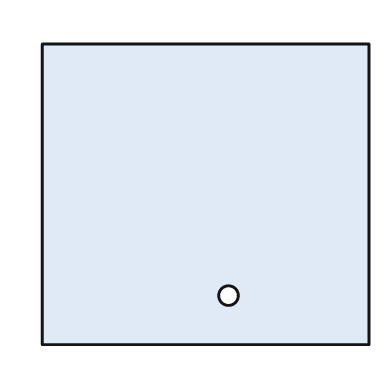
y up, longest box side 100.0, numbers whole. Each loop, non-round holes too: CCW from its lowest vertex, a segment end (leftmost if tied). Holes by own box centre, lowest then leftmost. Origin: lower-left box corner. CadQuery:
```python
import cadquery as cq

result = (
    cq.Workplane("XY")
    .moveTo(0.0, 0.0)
    .lineTo(100.0, 0.0)
    .lineTo(100.0, 92.0)
    .lineTo(0.0, 92.0)
    .close()
    .moveTo(57.0, 15.0)
    .circle(3.0)
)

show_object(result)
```